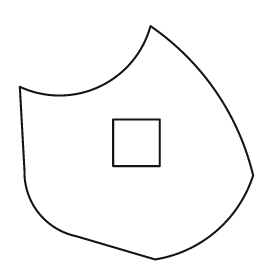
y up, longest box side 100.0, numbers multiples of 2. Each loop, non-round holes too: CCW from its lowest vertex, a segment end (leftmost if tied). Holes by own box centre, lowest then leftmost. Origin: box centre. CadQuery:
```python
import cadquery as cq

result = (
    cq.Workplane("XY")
    .moveTo(8.0, -50.0)
    .threePointArc((34.0, -38.0), (50.0, -14.0))
    .threePointArc((34.0, 22.0), (6.0, 50.0))
    .threePointArc((-16.0, 24.0), (-50.0, 24.0))
    .lineTo(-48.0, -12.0)
    .threePointArc((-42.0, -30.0), (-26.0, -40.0))
    .close()
    .moveTo(-10.0, -10.0)
    .lineTo(10.0, -10.0)
    .lineTo(10.0, 10.0)
    .lineTo(-10.0, 10.0)
    .close()
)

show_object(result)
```